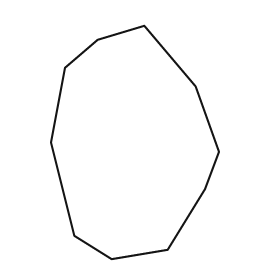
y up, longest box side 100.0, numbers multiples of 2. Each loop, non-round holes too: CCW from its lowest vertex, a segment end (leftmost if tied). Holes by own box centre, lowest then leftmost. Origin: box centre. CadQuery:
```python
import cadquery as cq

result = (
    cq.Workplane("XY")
    .moveTo(-10.0, -50.0)
    .lineTo(14.0, -46.0)
    .lineTo(30.0, -20.0)
    .lineTo(36.0, -4.0)
    .lineTo(26.0, 24.0)
    .lineTo(4.0, 50.0)
    .lineTo(-16.0, 44.0)
    .lineTo(-30.0, 32.0)
    .lineTo(-36.0, 0.0)
    .lineTo(-26.0, -40.0)
    .close()
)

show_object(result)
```